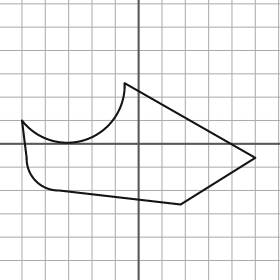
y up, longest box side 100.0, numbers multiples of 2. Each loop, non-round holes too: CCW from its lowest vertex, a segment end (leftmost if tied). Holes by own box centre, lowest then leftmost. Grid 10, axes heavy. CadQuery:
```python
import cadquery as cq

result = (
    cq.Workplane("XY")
    .moveTo(18.0, -26.0)
    .lineTo(50.0, -6.0)
    .lineTo(-6.0, 26.0)
    .threePointArc((-22.0, 2.0), (-50.0, 10.0))
    .lineTo(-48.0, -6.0)
    .threePointArc((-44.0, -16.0), (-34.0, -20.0))
    .close()
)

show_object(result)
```